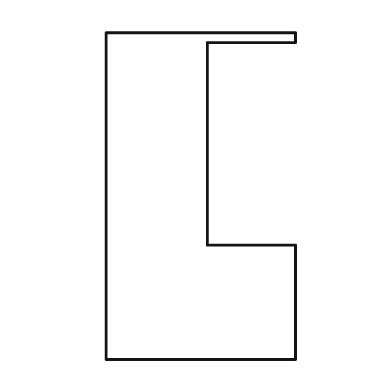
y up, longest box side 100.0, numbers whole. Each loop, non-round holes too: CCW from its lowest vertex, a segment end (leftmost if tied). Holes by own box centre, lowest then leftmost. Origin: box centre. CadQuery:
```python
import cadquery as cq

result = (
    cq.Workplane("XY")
    .moveTo(-29.0, -50.0)
    .lineTo(29.0, -50.0)
    .lineTo(29.0, -15.0)
    .lineTo(2.0, -15.0)
    .lineTo(2.0, 47.0)
    .lineTo(29.0, 47.0)
    .lineTo(29.0, 50.0)
    .lineTo(-29.0, 50.0)
    .close()
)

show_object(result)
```